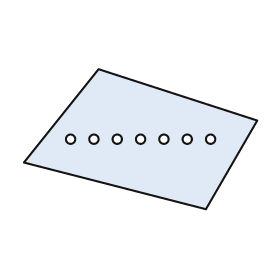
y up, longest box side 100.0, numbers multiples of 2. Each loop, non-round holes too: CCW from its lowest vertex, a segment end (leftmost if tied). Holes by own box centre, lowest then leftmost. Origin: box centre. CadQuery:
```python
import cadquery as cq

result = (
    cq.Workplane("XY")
    .moveTo(28.0, -30.0)
    .lineTo(50.0, 8.0)
    .lineTo(-18.0, 30.0)
    .lineTo(-50.0, -10.0)
    .close()
    .moveTo(-30.0, 0.0)
    .circle(2.0)
    .moveTo(-20.0, 0.0)
    .circle(2.0)
    .moveTo(-10.0, 0.0)
    .circle(2.0)
    .moveTo(0.0, 0.0)
    .circle(2.0)
    .moveTo(10.0, 0.0)
    .circle(2.0)
    .moveTo(20.0, 0.0)
    .circle(2.0)
    .moveTo(30.0, 0.0)
    .circle(2.0)
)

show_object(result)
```